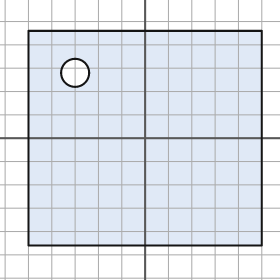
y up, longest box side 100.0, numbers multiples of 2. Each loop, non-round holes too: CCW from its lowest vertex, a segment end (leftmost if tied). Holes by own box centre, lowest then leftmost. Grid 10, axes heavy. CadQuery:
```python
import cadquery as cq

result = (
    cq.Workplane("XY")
    .moveTo(-50.0, -46.0)
    .lineTo(50.0, -46.0)
    .lineTo(50.0, 46.0)
    .lineTo(-50.0, 46.0)
    .close()
    .moveTo(-30.0, 28.0)
    .circle(6.0)
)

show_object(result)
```